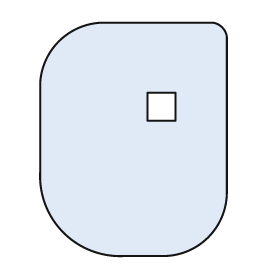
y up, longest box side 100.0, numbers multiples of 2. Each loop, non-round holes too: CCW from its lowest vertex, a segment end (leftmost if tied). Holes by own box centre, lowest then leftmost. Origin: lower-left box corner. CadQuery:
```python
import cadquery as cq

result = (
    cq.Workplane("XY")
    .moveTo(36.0, 0.0)
    .lineTo(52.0, 0.0)
    .threePointArc((72.0, 8.0), (80.0, 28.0))
    .lineTo(80.0, 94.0)
    .threePointArc((78.0, 98.0), (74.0, 100.0))
    .lineTo(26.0, 100.0)
    .threePointArc((8.0, 92.0), (0.0, 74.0))
    .lineTo(0.0, 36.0)
    .threePointArc((10.0, 10.0), (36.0, 0.0))
    .close()
    .moveTo(46.0, 58.0)
    .lineTo(58.0, 58.0)
    .lineTo(58.0, 70.0)
    .lineTo(46.0, 70.0)
    .close()
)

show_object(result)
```